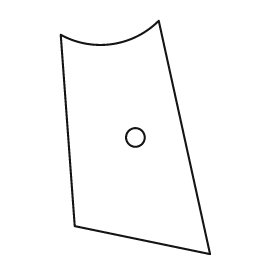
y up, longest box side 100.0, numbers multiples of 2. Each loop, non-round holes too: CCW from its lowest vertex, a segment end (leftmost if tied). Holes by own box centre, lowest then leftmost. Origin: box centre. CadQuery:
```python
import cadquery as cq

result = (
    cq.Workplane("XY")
    .moveTo(32.0, -50.0)
    .lineTo(10.0, 50.0)
    .threePointArc((-10.0, 40.0), (-32.0, 44.0))
    .lineTo(-26.0, -38.0)
    .close()
    .moveTo(0.0, 0.0)
    .circle(4.0)
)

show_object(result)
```